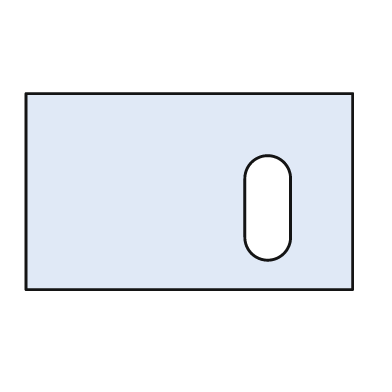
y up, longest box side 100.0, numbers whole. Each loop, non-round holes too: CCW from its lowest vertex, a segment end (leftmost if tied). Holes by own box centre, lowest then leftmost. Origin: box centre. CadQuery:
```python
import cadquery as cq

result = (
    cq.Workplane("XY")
    .moveTo(-50.0, -30.0)
    .lineTo(50.0, -30.0)
    .lineTo(50.0, 30.0)
    .lineTo(-50.0, 30.0)
    .close()
    .moveTo(17.0, -14.0)
    .threePointArc((24.0, -21.0), (31.0, -14.0))
    .lineTo(31.0, 4.0)
    .threePointArc((24.0, 11.0), (17.0, 4.0))
    .close()
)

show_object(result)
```